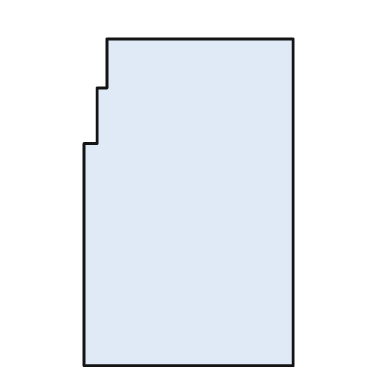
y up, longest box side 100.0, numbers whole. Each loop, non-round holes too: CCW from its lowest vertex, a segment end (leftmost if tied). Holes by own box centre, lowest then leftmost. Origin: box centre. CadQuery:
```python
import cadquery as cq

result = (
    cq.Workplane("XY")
    .moveTo(-32.0, -50.0)
    .lineTo(32.0, -50.0)
    .lineTo(32.0, 50.0)
    .lineTo(-25.0, 50.0)
    .lineTo(-25.0, 35.0)
    .lineTo(-28.0, 35.0)
    .lineTo(-28.0, 18.0)
    .lineTo(-32.0, 18.0)
    .close()
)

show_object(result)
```